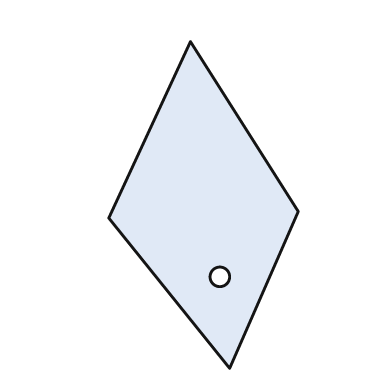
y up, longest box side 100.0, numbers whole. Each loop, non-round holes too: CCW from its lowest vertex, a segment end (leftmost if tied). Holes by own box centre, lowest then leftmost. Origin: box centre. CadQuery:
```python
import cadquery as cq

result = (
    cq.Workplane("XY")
    .moveTo(8.0, -50.0)
    .lineTo(29.0, -2.0)
    .lineTo(-4.0, 50.0)
    .lineTo(-29.0, -4.0)
    .close()
    .moveTo(5.0, -22.0)
    .circle(3.0)
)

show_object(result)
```